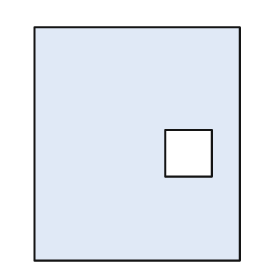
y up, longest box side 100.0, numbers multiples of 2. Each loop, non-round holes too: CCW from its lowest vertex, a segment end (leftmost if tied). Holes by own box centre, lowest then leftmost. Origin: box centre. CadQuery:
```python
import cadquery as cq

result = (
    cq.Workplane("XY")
    .moveTo(-44.0, -50.0)
    .lineTo(44.0, -50.0)
    .lineTo(44.0, 50.0)
    .lineTo(-44.0, 50.0)
    .close()
    .moveTo(12.0, -14.0)
    .lineTo(32.0, -14.0)
    .lineTo(32.0, 6.0)
    .lineTo(12.0, 6.0)
    .close()
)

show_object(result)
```